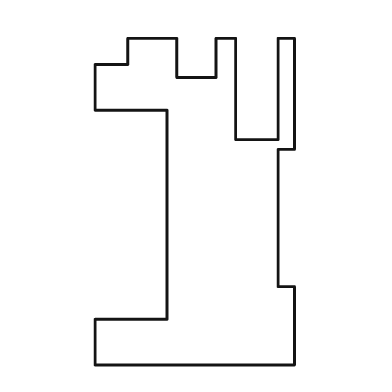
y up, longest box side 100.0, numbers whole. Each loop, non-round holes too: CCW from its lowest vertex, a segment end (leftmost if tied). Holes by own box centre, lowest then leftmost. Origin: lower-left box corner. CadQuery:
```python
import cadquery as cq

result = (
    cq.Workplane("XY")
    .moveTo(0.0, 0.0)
    .lineTo(61.0, 0.0)
    .lineTo(61.0, 24.0)
    .lineTo(56.0, 24.0)
    .lineTo(56.0, 66.0)
    .lineTo(61.0, 66.0)
    .lineTo(61.0, 100.0)
    .lineTo(56.0, 100.0)
    .lineTo(56.0, 69.0)
    .lineTo(43.0, 69.0)
    .lineTo(43.0, 100.0)
    .lineTo(37.0, 100.0)
    .lineTo(37.0, 88.0)
    .lineTo(25.0, 88.0)
    .lineTo(25.0, 100.0)
    .lineTo(10.0, 100.0)
    .lineTo(10.0, 92.0)
    .lineTo(0.0, 92.0)
    .lineTo(0.0, 78.0)
    .lineTo(22.0, 78.0)
    .lineTo(22.0, 14.0)
    .lineTo(0.0, 14.0)
    .close()
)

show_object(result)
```